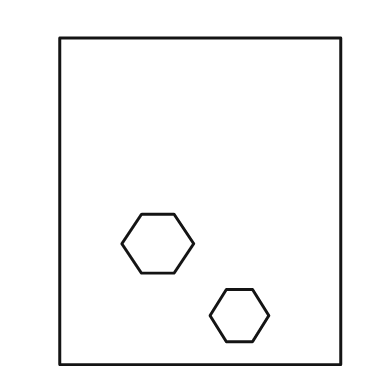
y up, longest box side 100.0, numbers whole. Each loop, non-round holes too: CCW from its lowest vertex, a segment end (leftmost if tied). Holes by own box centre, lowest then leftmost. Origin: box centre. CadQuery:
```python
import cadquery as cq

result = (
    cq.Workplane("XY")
    .moveTo(-43.0, -50.0)
    .lineTo(43.0, -50.0)
    .lineTo(43.0, 50.0)
    .lineTo(-43.0, 50.0)
    .close()
    .moveTo(8.0, -43.0)
    .lineTo(16.0, -43.0)
    .lineTo(21.0, -35.0)
    .lineTo(16.0, -27.0)
    .lineTo(8.0, -27.0)
    .lineTo(3.0, -35.0)
    .close()
    .moveTo(-18.0, -22.0)
    .lineTo(-8.0, -22.0)
    .lineTo(-2.0, -13.0)
    .lineTo(-8.0, -4.0)
    .lineTo(-18.0, -4.0)
    .lineTo(-24.0, -13.0)
    .close()
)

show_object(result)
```